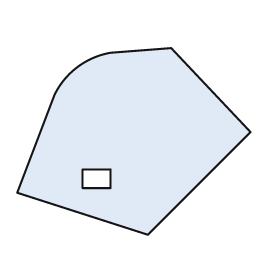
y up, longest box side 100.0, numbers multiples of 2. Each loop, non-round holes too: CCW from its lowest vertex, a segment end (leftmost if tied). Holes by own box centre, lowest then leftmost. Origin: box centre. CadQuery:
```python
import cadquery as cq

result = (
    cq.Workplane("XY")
    .moveTo(6.0, -40.0)
    .lineTo(50.0, 4.0)
    .lineTo(16.0, 40.0)
    .lineTo(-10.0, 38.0)
    .threePointArc((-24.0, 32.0), (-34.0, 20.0))
    .lineTo(-50.0, -22.0)
    .close()
    .moveTo(-22.0, -20.0)
    .lineTo(-10.0, -20.0)
    .lineTo(-10.0, -12.0)
    .lineTo(-22.0, -12.0)
    .close()
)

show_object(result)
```